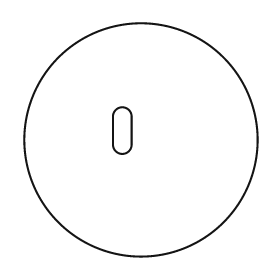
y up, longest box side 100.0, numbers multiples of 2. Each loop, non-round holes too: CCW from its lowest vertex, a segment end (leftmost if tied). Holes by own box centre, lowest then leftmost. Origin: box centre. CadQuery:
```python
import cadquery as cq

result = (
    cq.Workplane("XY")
    .moveTo(0.0, 0.0)
    .circle(50.0)
    .moveTo(-12.0, -2.0)
    .threePointArc((-8.0, -6.0), (-4.0, -2.0))
    .lineTo(-4.0, 10.0)
    .threePointArc((-8.0, 14.0), (-12.0, 10.0))
    .close()
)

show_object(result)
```